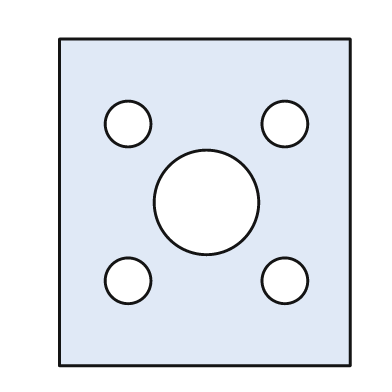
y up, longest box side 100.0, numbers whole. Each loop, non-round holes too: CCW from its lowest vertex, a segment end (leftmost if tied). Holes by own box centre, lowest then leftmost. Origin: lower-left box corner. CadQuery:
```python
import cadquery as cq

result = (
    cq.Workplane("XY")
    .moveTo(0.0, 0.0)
    .lineTo(89.0, 0.0)
    .lineTo(89.0, 100.0)
    .lineTo(0.0, 100.0)
    .close()
    .moveTo(21.0, 26.0)
    .circle(7.0)
    .moveTo(69.0, 26.0)
    .circle(7.0)
    .moveTo(45.0, 50.0)
    .circle(16.0)
    .moveTo(21.0, 74.0)
    .circle(7.0)
    .moveTo(69.0, 74.0)
    .circle(7.0)
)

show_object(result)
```